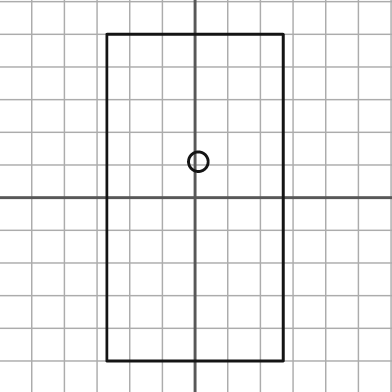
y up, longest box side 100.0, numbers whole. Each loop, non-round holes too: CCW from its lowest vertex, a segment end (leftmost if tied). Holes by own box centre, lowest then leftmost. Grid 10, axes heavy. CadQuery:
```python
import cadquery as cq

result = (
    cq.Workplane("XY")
    .moveTo(-27.0, -50.0)
    .lineTo(27.0, -50.0)
    .lineTo(27.0, 50.0)
    .lineTo(-27.0, 50.0)
    .close()
    .moveTo(1.0, 11.0)
    .circle(3.0)
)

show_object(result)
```